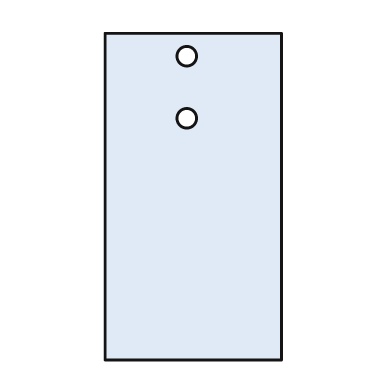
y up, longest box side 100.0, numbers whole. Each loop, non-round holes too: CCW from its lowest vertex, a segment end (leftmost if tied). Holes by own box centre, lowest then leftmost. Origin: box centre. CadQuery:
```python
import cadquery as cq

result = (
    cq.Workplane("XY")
    .moveTo(-27.0, -50.0)
    .lineTo(27.0, -50.0)
    .lineTo(27.0, 50.0)
    .lineTo(-27.0, 50.0)
    .close()
    .moveTo(-2.0, 24.0)
    .circle(3.0)
    .moveTo(-2.0, 43.0)
    .circle(3.0)
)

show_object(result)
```